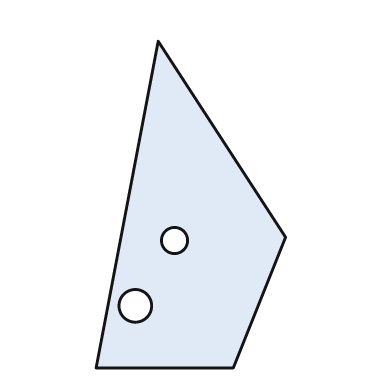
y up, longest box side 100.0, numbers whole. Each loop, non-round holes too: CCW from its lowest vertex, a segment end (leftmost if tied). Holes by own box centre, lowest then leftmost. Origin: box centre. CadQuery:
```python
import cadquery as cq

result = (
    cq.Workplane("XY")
    .moveTo(-29.0, -50.0)
    .lineTo(13.0, -50.0)
    .lineTo(29.0, -10.0)
    .lineTo(-10.0, 50.0)
    .close()
    .moveTo(-17.0, -31.0)
    .circle(5.0)
    .moveTo(-5.0, -11.0)
    .circle(4.0)
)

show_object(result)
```